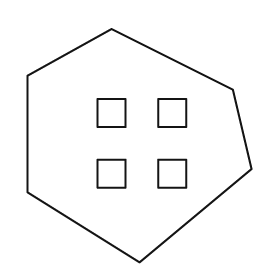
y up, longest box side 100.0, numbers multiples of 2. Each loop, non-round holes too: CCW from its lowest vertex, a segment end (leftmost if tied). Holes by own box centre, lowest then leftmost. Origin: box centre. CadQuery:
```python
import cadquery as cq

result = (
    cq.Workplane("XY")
    .moveTo(0.0, -50.0)
    .lineTo(48.0, -10.0)
    .lineTo(40.0, 24.0)
    .lineTo(-12.0, 50.0)
    .lineTo(-48.0, 30.0)
    .lineTo(-48.0, -20.0)
    .close()
    .moveTo(-18.0, -18.0)
    .lineTo(-6.0, -18.0)
    .lineTo(-6.0, -6.0)
    .lineTo(-18.0, -6.0)
    .close()
    .moveTo(8.0, -18.0)
    .lineTo(20.0, -18.0)
    .lineTo(20.0, -6.0)
    .lineTo(8.0, -6.0)
    .close()
    .moveTo(-18.0, 8.0)
    .lineTo(-6.0, 8.0)
    .lineTo(-6.0, 20.0)
    .lineTo(-18.0, 20.0)
    .close()
    .moveTo(8.0, 8.0)
    .lineTo(20.0, 8.0)
    .lineTo(20.0, 20.0)
    .lineTo(8.0, 20.0)
    .close()
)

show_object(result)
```